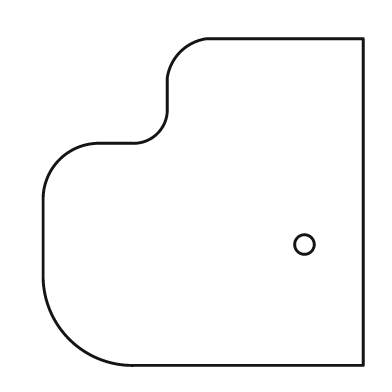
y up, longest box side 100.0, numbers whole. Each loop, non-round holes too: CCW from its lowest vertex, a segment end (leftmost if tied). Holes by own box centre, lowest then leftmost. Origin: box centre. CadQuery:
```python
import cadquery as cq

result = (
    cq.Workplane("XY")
    .moveTo(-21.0, -50.0)
    .lineTo(49.0, -50.0)
    .lineTo(49.0, 50.0)
    .lineTo(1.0, 50.0)
    .threePointArc((-7.0, 46.0), (-11.0, 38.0))
    .lineTo(-11.0, 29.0)
    .threePointArc((-14.0, 21.0), (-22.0, 18.0))
    .lineTo(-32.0, 18.0)
    .threePointArc((-44.0, 13.0), (-49.0, 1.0))
    .lineTo(-49.0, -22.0)
    .threePointArc((-41.0, -42.0), (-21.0, -50.0))
    .close()
    .moveTo(31.0, -13.0)
    .circle(3.0)
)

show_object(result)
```